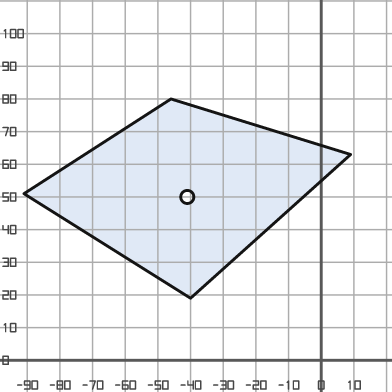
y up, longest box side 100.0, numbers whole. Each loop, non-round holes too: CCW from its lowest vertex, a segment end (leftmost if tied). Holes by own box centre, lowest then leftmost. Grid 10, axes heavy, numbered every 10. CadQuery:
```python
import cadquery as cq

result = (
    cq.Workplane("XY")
    .moveTo(-40.0, 19.0)
    .lineTo(9.0, 63.0)
    .lineTo(-46.0, 80.0)
    .lineTo(-91.0, 51.0)
    .close()
    .moveTo(-41.0, 50.0)
    .circle(2.0)
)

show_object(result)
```